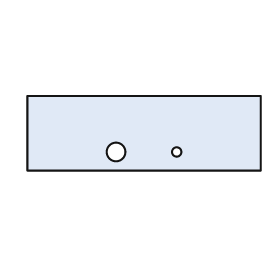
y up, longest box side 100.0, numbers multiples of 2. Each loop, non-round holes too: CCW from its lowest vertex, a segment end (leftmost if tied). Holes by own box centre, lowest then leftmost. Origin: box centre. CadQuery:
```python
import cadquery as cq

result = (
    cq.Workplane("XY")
    .moveTo(-50.0, -16.0)
    .lineTo(50.0, -16.0)
    .lineTo(50.0, 16.0)
    .lineTo(-50.0, 16.0)
    .close()
    .moveTo(-12.0, -8.0)
    .circle(4.0)
    .moveTo(14.0, -8.0)
    .circle(2.0)
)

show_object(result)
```